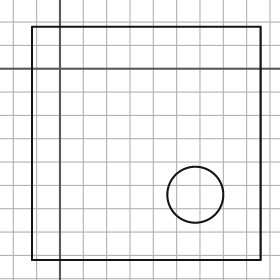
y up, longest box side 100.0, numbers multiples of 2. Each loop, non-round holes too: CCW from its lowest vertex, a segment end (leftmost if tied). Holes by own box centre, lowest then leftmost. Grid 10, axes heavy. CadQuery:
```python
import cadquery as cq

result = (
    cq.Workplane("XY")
    .moveTo(-12.0, -82.0)
    .lineTo(86.0, -82.0)
    .lineTo(86.0, 18.0)
    .lineTo(-12.0, 18.0)
    .close()
    .moveTo(58.0, -54.0)
    .circle(12.0)
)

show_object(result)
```